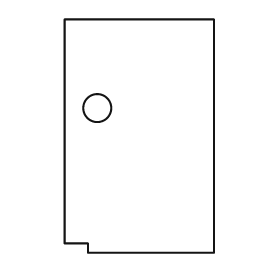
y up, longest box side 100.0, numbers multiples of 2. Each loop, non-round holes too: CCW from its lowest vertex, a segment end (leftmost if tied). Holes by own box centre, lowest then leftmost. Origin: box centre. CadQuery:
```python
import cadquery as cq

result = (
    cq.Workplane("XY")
    .moveTo(-22.0, -50.0)
    .lineTo(32.0, -50.0)
    .lineTo(32.0, 50.0)
    .lineTo(-32.0, 50.0)
    .lineTo(-32.0, -46.0)
    .lineTo(-22.0, -46.0)
    .close()
    .moveTo(-18.0, 12.0)
    .circle(6.0)
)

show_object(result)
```